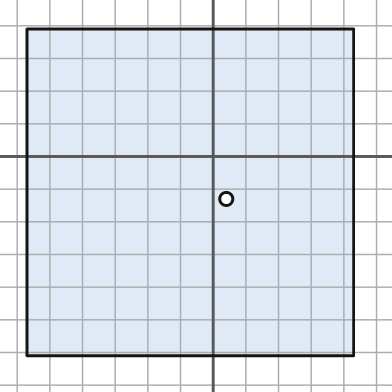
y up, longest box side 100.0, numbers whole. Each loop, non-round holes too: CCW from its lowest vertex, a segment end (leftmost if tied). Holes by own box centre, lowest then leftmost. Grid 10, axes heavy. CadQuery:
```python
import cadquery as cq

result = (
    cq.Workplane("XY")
    .moveTo(-57.0, -61.0)
    .lineTo(43.0, -61.0)
    .lineTo(43.0, 39.0)
    .lineTo(-57.0, 39.0)
    .close()
    .moveTo(4.0, -13.0)
    .circle(2.0)
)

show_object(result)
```